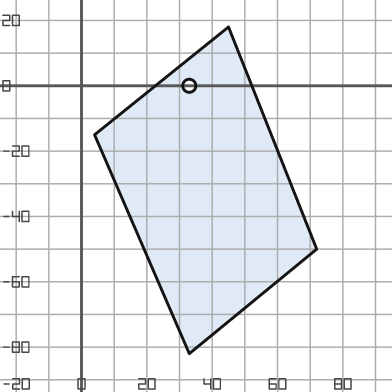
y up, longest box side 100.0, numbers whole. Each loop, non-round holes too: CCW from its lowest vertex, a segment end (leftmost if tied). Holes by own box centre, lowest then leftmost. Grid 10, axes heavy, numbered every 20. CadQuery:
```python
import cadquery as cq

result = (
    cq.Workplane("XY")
    .moveTo(33.0, -82.0)
    .lineTo(72.0, -50.0)
    .lineTo(45.0, 18.0)
    .lineTo(4.0, -15.0)
    .close()
    .moveTo(33.0, 0.0)
    .circle(2.0)
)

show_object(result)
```